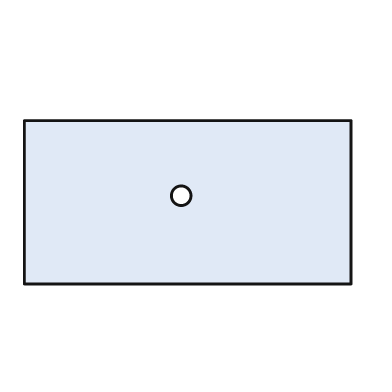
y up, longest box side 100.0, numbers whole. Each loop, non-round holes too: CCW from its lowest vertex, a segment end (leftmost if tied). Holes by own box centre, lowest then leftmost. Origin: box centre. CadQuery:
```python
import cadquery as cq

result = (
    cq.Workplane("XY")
    .moveTo(-50.0, -25.0)
    .lineTo(50.0, -25.0)
    .lineTo(50.0, 25.0)
    .lineTo(-50.0, 25.0)
    .close()
    .moveTo(-2.0, 2.0)
    .circle(3.0)
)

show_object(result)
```